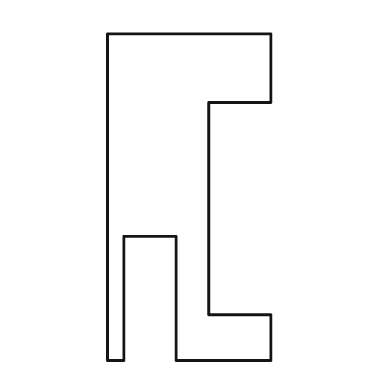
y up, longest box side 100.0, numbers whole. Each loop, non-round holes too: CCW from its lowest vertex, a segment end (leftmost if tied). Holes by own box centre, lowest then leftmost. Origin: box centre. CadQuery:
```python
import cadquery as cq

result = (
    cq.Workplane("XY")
    .moveTo(-25.0, -50.0)
    .lineTo(-20.0, -50.0)
    .lineTo(-20.0, -12.0)
    .lineTo(-4.0, -12.0)
    .lineTo(-4.0, -50.0)
    .lineTo(25.0, -50.0)
    .lineTo(25.0, -36.0)
    .lineTo(6.0, -36.0)
    .lineTo(6.0, 29.0)
    .lineTo(25.0, 29.0)
    .lineTo(25.0, 50.0)
    .lineTo(-25.0, 50.0)
    .close()
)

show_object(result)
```